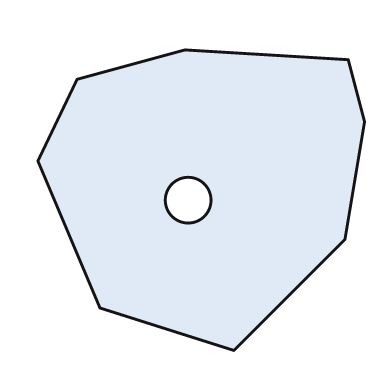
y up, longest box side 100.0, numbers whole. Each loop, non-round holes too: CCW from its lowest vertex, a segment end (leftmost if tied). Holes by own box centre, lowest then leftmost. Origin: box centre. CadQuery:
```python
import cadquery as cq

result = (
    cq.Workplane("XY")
    .moveTo(10.0, -46.0)
    .lineTo(44.0, -12.0)
    .lineTo(50.0, 24.0)
    .lineTo(45.0, 43.0)
    .lineTo(-5.0, 46.0)
    .lineTo(-38.0, 37.0)
    .lineTo(-50.0, 12.0)
    .lineTo(-31.0, -33.0)
    .close()
    .moveTo(-4.0, 0.0)
    .circle(7.0)
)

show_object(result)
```